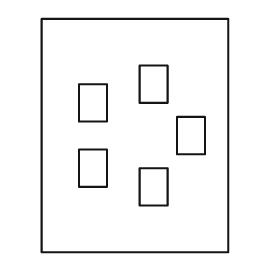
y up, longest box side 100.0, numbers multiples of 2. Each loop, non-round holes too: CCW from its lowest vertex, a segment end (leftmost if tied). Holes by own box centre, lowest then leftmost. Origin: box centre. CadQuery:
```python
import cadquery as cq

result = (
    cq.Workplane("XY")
    .moveTo(-40.0, -50.0)
    .lineTo(40.0, -50.0)
    .lineTo(40.0, 50.0)
    .lineTo(-40.0, 50.0)
    .close()
    .moveTo(2.0, -30.0)
    .lineTo(14.0, -30.0)
    .lineTo(14.0, -14.0)
    .lineTo(2.0, -14.0)
    .close()
    .moveTo(-24.0, -22.0)
    .lineTo(-12.0, -22.0)
    .lineTo(-12.0, -6.0)
    .lineTo(-24.0, -6.0)
    .close()
    .moveTo(18.0, -8.0)
    .lineTo(30.0, -8.0)
    .lineTo(30.0, 8.0)
    .lineTo(18.0, 8.0)
    .close()
    .moveTo(-24.0, 6.0)
    .lineTo(-12.0, 6.0)
    .lineTo(-12.0, 22.0)
    .lineTo(-24.0, 22.0)
    .close()
    .moveTo(2.0, 14.0)
    .lineTo(14.0, 14.0)
    .lineTo(14.0, 30.0)
    .lineTo(2.0, 30.0)
    .close()
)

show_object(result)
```